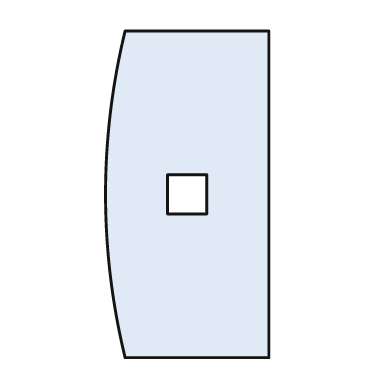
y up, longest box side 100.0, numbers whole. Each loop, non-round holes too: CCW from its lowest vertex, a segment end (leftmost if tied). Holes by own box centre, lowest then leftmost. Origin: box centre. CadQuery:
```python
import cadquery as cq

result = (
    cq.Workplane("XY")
    .moveTo(-19.0, -50.0)
    .lineTo(25.0, -50.0)
    .lineTo(25.0, 50.0)
    .lineTo(-19.0, 50.0)
    .threePointArc((-25.0, 0.0), (-19.0, -50.0))
    .close()
    .moveTo(-6.0, -6.0)
    .lineTo(6.0, -6.0)
    .lineTo(6.0, 6.0)
    .lineTo(-6.0, 6.0)
    .close()
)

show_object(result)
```